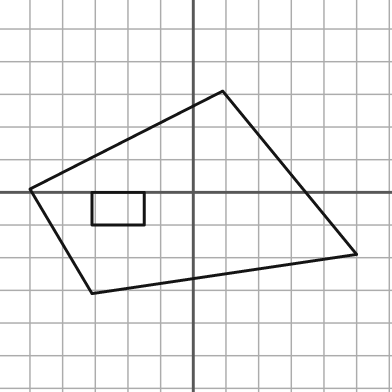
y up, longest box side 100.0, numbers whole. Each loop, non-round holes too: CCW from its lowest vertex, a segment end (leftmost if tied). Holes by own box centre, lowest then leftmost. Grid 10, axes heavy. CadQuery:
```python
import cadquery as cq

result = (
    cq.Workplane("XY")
    .moveTo(-31.0, -31.0)
    .lineTo(50.0, -19.0)
    .lineTo(9.0, 31.0)
    .lineTo(-50.0, 1.0)
    .close()
    .moveTo(-31.0, -10.0)
    .lineTo(-15.0, -10.0)
    .lineTo(-15.0, 0.0)
    .lineTo(-31.0, 0.0)
    .close()
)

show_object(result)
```